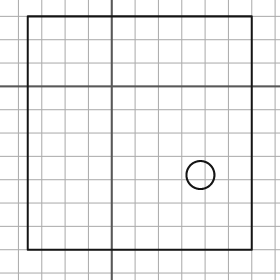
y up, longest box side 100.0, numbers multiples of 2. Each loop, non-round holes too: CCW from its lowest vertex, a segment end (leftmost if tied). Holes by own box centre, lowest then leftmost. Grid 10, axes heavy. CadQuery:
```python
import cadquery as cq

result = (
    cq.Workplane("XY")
    .moveTo(-36.0, -70.0)
    .lineTo(60.0, -70.0)
    .lineTo(60.0, 30.0)
    .lineTo(-36.0, 30.0)
    .close()
    .moveTo(38.0, -38.0)
    .circle(6.0)
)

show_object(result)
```